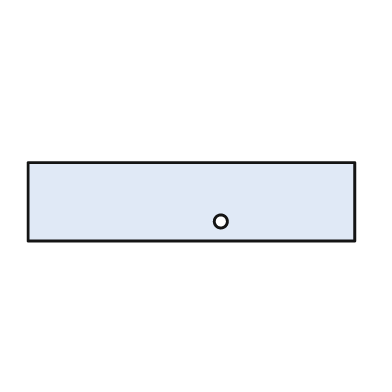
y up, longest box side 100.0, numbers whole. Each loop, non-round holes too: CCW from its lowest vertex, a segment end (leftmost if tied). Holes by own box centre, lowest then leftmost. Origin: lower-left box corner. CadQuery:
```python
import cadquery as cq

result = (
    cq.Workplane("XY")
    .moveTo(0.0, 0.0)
    .lineTo(100.0, 0.0)
    .lineTo(100.0, 24.0)
    .lineTo(0.0, 24.0)
    .close()
    .moveTo(59.0, 6.0)
    .circle(2.0)
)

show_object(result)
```